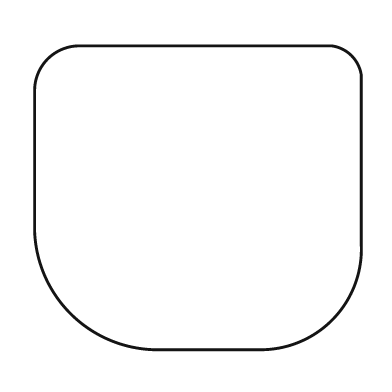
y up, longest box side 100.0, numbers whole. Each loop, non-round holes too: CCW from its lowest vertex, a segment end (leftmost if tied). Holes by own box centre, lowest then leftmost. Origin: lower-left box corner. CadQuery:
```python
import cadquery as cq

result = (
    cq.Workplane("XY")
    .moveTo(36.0, 0.0)
    .lineTo(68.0, 0.0)
    .threePointArc((91.0, 9.0), (100.0, 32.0))
    .lineTo(100.0, 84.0)
    .threePointArc((97.0, 90.0), (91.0, 93.0))
    .lineTo(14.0, 93.0)
    .threePointArc((4.0, 89.0), (0.0, 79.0))
    .lineTo(0.0, 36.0)
    .threePointArc((11.0, 11.0), (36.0, 0.0))
    .close()
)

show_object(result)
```